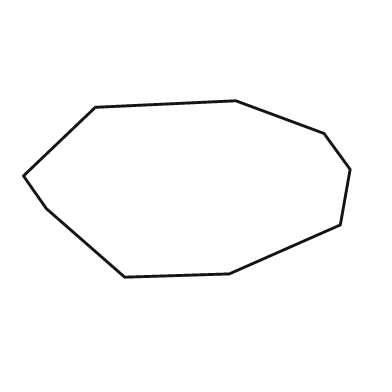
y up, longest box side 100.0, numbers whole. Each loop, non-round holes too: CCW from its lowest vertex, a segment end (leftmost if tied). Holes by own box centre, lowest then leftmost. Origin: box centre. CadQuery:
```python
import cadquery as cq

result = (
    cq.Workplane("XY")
    .moveTo(-19.0, -27.0)
    .lineTo(13.0, -26.0)
    .lineTo(47.0, -11.0)
    .lineTo(50.0, 6.0)
    .lineTo(42.0, 17.0)
    .lineTo(15.0, 27.0)
    .lineTo(-28.0, 25.0)
    .lineTo(-50.0, 4.0)
    .lineTo(-43.0, -6.0)
    .close()
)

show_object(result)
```